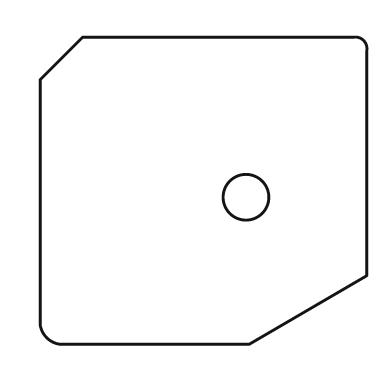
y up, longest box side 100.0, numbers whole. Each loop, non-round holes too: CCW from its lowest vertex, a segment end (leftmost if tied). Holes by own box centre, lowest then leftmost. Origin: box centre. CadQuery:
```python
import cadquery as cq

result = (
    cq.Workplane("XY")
    .moveTo(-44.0, -47.0)
    .lineTo(14.0, -47.0)
    .lineTo(50.0, -26.0)
    .lineTo(50.0, 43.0)
    .threePointArc((49.0, 46.0), (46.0, 47.0))
    .lineTo(-37.0, 47.0)
    .lineTo(-50.0, 34.0)
    .lineTo(-50.0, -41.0)
    .threePointArc((-48.0, -45.0), (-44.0, -47.0))
    .close()
    .moveTo(13.0, -2.0)
    .circle(7.0)
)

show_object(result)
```